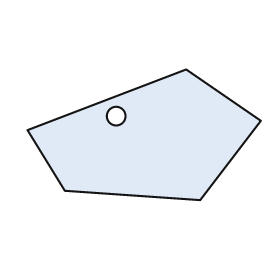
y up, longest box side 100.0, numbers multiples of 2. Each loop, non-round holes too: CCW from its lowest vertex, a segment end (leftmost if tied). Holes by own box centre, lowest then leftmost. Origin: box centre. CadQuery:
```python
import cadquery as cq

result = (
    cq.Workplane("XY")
    .moveTo(24.0, -28.0)
    .lineTo(50.0, 6.0)
    .lineTo(18.0, 28.0)
    .lineTo(-50.0, 2.0)
    .lineTo(-34.0, -24.0)
    .close()
    .moveTo(-12.0, 8.0)
    .circle(4.0)
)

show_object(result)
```